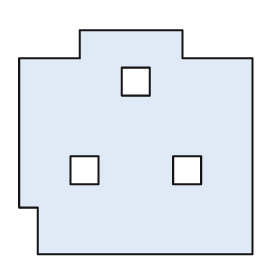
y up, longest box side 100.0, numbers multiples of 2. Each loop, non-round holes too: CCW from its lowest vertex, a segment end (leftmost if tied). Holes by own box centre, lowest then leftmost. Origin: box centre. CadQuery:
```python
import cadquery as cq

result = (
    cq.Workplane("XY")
    .moveTo(-42.0, -48.0)
    .lineTo(50.0, -48.0)
    .lineTo(50.0, 36.0)
    .lineTo(20.0, 36.0)
    .lineTo(20.0, 48.0)
    .lineTo(-24.0, 48.0)
    .lineTo(-24.0, 36.0)
    .lineTo(-50.0, 36.0)
    .lineTo(-50.0, -28.0)
    .lineTo(-42.0, -28.0)
    .close()
    .moveTo(-28.0, -18.0)
    .lineTo(-16.0, -18.0)
    .lineTo(-16.0, -6.0)
    .lineTo(-28.0, -6.0)
    .close()
    .moveTo(16.0, -18.0)
    .lineTo(28.0, -18.0)
    .lineTo(28.0, -6.0)
    .lineTo(16.0, -6.0)
    .close()
    .moveTo(-6.0, 20.0)
    .lineTo(6.0, 20.0)
    .lineTo(6.0, 32.0)
    .lineTo(-6.0, 32.0)
    .close()
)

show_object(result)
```